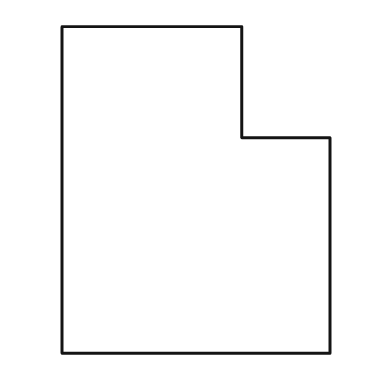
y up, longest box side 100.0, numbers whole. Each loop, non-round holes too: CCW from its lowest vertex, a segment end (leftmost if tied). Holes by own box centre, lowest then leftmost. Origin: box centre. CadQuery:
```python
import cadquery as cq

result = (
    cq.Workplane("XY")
    .moveTo(-41.0, -50.0)
    .lineTo(41.0, -50.0)
    .lineTo(41.0, 16.0)
    .lineTo(14.0, 16.0)
    .lineTo(14.0, 50.0)
    .lineTo(-41.0, 50.0)
    .close()
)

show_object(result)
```